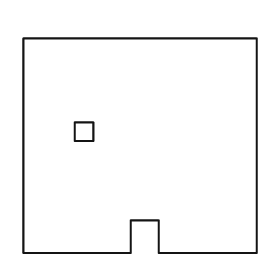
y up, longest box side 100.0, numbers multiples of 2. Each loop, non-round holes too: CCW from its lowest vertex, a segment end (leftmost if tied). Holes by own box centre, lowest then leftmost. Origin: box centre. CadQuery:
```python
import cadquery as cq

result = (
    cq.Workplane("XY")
    .moveTo(-50.0, -46.0)
    .lineTo(-4.0, -46.0)
    .lineTo(-4.0, -32.0)
    .lineTo(8.0, -32.0)
    .lineTo(8.0, -46.0)
    .lineTo(50.0, -46.0)
    .lineTo(50.0, 46.0)
    .lineTo(-50.0, 46.0)
    .close()
    .moveTo(-28.0, 2.0)
    .lineTo(-20.0, 2.0)
    .lineTo(-20.0, 10.0)
    .lineTo(-28.0, 10.0)
    .close()
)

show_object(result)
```